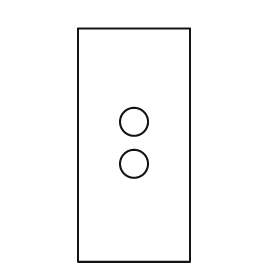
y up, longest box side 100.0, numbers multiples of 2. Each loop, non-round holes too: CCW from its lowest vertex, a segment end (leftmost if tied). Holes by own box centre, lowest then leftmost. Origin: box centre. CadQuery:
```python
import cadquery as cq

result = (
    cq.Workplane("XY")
    .moveTo(-24.0, -50.0)
    .lineTo(24.0, -50.0)
    .lineTo(24.0, 50.0)
    .lineTo(-24.0, 50.0)
    .close()
    .moveTo(0.0, -8.0)
    .circle(6.0)
    .moveTo(0.0, 10.0)
    .circle(6.0)
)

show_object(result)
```